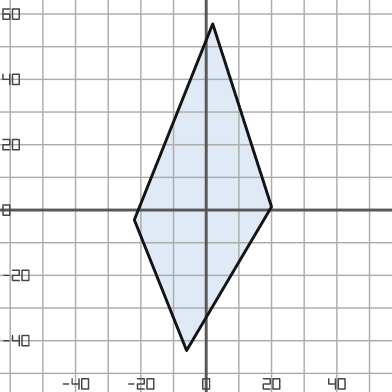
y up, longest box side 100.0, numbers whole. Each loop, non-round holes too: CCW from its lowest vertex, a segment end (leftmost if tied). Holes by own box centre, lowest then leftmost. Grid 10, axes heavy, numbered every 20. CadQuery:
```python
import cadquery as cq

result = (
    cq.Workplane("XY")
    .moveTo(-6.0, -43.0)
    .lineTo(20.0, 1.0)
    .lineTo(2.0, 57.0)
    .lineTo(-22.0, -3.0)
    .close()
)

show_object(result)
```